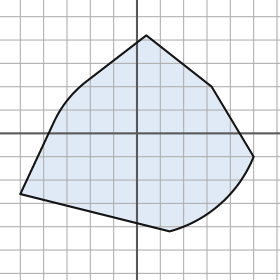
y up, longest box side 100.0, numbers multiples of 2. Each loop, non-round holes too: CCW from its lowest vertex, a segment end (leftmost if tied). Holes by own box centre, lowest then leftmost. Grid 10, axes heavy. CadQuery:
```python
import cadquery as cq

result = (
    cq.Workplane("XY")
    .moveTo(14.0, -42.0)
    .threePointArc((36.0, -30.0), (50.0, -10.0))
    .lineTo(32.0, 20.0)
    .lineTo(4.0, 42.0)
    .lineTo(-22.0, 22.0)
    .threePointArc((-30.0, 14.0), (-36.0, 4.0))
    .lineTo(-50.0, -26.0)
    .close()
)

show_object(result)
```